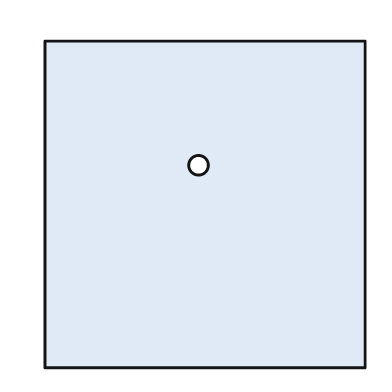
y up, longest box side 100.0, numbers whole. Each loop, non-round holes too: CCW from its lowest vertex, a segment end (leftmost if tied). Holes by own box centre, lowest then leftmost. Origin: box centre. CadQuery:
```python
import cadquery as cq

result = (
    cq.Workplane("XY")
    .moveTo(-49.0, -50.0)
    .lineTo(49.0, -50.0)
    .lineTo(49.0, 50.0)
    .lineTo(-49.0, 50.0)
    .close()
    .moveTo(-2.0, 12.0)
    .circle(3.0)
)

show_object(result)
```